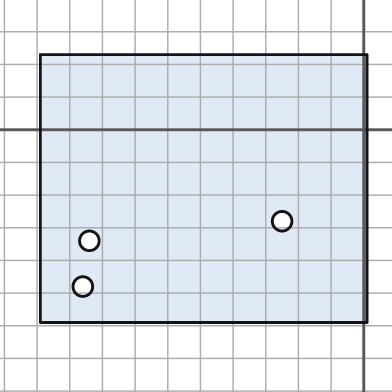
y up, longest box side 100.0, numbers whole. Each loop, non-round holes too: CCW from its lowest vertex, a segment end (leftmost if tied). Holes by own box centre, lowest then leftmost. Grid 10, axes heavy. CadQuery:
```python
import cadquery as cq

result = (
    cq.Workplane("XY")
    .moveTo(-99.0, -59.0)
    .lineTo(1.0, -59.0)
    .lineTo(1.0, 23.0)
    .lineTo(-99.0, 23.0)
    .close()
    .moveTo(-86.0, -48.0)
    .circle(3.0)
    .moveTo(-84.0, -34.0)
    .circle(3.0)
    .moveTo(-25.0, -28.0)
    .circle(3.0)
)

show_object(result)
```